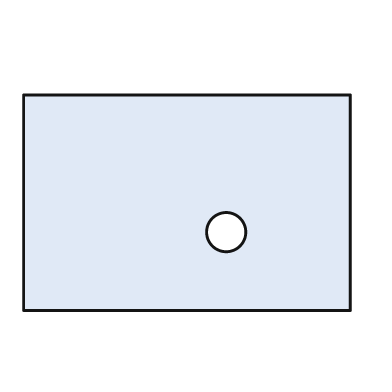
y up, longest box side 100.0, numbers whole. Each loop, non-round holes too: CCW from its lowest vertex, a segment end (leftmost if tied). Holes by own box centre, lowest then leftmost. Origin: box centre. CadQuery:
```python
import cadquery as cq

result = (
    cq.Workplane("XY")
    .moveTo(-50.0, -33.0)
    .lineTo(50.0, -33.0)
    .lineTo(50.0, 33.0)
    .lineTo(-50.0, 33.0)
    .close()
    .moveTo(12.0, -9.0)
    .circle(6.0)
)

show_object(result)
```